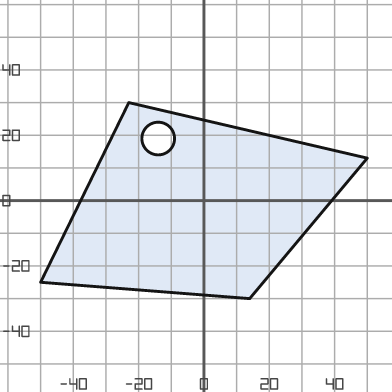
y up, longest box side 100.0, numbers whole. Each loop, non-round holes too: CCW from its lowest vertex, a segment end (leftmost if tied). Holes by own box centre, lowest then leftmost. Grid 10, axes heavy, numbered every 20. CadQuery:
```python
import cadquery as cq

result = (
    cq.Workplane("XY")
    .moveTo(14.0, -30.0)
    .lineTo(50.0, 13.0)
    .lineTo(-23.0, 30.0)
    .lineTo(-50.0, -25.0)
    .close()
    .moveTo(-14.0, 19.0)
    .circle(5.0)
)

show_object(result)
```